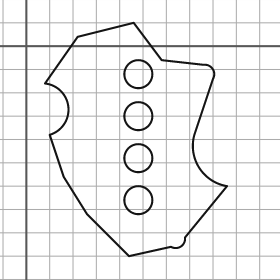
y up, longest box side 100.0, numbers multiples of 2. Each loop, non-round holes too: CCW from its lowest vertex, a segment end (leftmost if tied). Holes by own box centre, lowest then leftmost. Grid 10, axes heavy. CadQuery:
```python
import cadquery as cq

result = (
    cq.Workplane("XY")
    .moveTo(44.0, -90.0)
    .lineTo(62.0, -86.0)
    .threePointArc((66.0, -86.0), (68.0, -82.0))
    .lineTo(86.0, -60.0)
    .threePointArc((74.0, -52.0), (72.0, -38.0))
    .lineTo(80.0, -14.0)
    .threePointArc((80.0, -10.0), (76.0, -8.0))
    .lineTo(58.0, -6.0)
    .lineTo(46.0, 10.0)
    .lineTo(22.0, 4.0)
    .lineTo(8.0, -16.0)
    .threePointArc((18.0, -26.0), (10.0, -38.0))
    .lineTo(16.0, -56.0)
    .lineTo(26.0, -72.0)
    .close()
    .moveTo(48.0, -66.0)
    .circle(6.0)
    .moveTo(48.0, -48.0)
    .circle(6.0)
    .moveTo(48.0, -30.0)
    .circle(6.0)
    .moveTo(48.0, -12.0)
    .circle(6.0)
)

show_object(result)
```